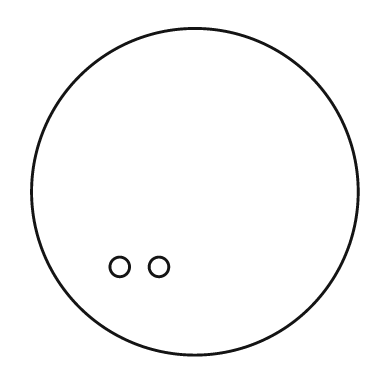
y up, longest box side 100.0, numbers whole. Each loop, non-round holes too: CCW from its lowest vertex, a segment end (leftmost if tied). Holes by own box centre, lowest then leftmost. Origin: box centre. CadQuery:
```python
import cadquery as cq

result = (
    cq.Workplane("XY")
    .moveTo(0.0, 0.0)
    .circle(50.0)
    .moveTo(-23.0, -23.0)
    .circle(3.0)
    .moveTo(-11.0, -23.0)
    .circle(3.0)
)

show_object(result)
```